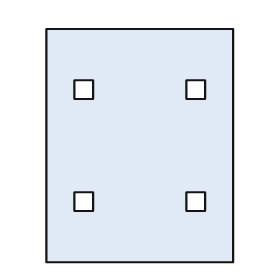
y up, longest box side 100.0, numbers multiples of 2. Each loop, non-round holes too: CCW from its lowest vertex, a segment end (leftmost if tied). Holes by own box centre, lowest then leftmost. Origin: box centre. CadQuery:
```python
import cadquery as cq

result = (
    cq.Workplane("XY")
    .moveTo(-40.0, -50.0)
    .lineTo(40.0, -50.0)
    .lineTo(40.0, 50.0)
    .lineTo(-40.0, 50.0)
    .close()
    .moveTo(-28.0, -28.0)
    .lineTo(-20.0, -28.0)
    .lineTo(-20.0, -20.0)
    .lineTo(-28.0, -20.0)
    .close()
    .moveTo(20.0, -28.0)
    .lineTo(28.0, -28.0)
    .lineTo(28.0, -20.0)
    .lineTo(20.0, -20.0)
    .close()
    .moveTo(-28.0, 20.0)
    .lineTo(-20.0, 20.0)
    .lineTo(-20.0, 28.0)
    .lineTo(-28.0, 28.0)
    .close()
    .moveTo(20.0, 20.0)
    .lineTo(28.0, 20.0)
    .lineTo(28.0, 28.0)
    .lineTo(20.0, 28.0)
    .close()
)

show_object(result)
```